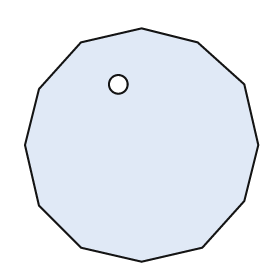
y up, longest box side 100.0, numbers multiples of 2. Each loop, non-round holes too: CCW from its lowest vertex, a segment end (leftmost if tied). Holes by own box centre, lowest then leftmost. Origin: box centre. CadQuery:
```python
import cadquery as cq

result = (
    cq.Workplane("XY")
    .moveTo(0.0, -50.0)
    .lineTo(26.0, -44.0)
    .lineTo(44.0, -24.0)
    .lineTo(50.0, 0.0)
    .lineTo(44.0, 26.0)
    .lineTo(24.0, 44.0)
    .lineTo(0.0, 50.0)
    .lineTo(-26.0, 44.0)
    .lineTo(-44.0, 24.0)
    .lineTo(-50.0, 0.0)
    .lineTo(-44.0, -26.0)
    .lineTo(-26.0, -44.0)
    .close()
    .moveTo(-10.0, 26.0)
    .circle(4.0)
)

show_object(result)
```